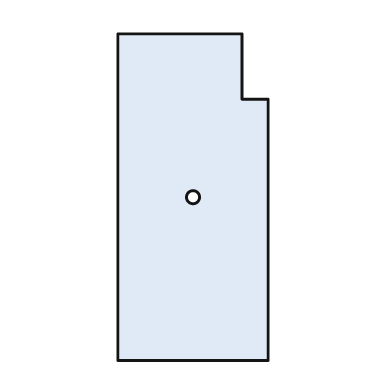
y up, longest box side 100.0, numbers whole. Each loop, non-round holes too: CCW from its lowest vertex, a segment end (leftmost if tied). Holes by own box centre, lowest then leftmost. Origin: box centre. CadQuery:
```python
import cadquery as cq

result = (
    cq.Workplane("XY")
    .moveTo(-23.0, -50.0)
    .lineTo(23.0, -50.0)
    .lineTo(23.0, 30.0)
    .lineTo(15.0, 30.0)
    .lineTo(15.0, 50.0)
    .lineTo(-23.0, 50.0)
    .close()
    .moveTo(0.0, 0.0)
    .circle(2.0)
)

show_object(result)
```